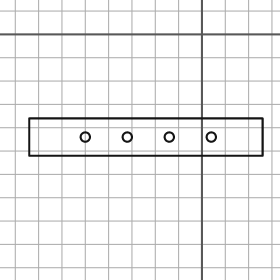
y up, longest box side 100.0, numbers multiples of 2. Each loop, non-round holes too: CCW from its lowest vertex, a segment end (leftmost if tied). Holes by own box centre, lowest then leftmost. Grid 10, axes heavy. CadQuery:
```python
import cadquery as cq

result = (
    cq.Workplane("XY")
    .moveTo(-74.0, -52.0)
    .lineTo(26.0, -52.0)
    .lineTo(26.0, -36.0)
    .lineTo(-74.0, -36.0)
    .close()
    .moveTo(-50.0, -44.0)
    .circle(2.0)
    .moveTo(-32.0, -44.0)
    .circle(2.0)
    .moveTo(-14.0, -44.0)
    .circle(2.0)
    .moveTo(4.0, -44.0)
    .circle(2.0)
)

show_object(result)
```